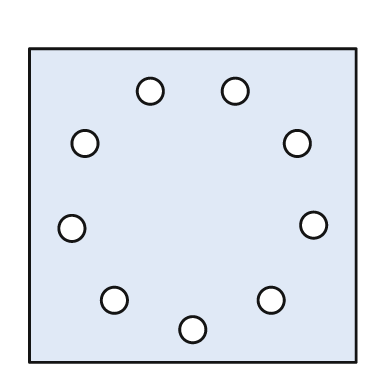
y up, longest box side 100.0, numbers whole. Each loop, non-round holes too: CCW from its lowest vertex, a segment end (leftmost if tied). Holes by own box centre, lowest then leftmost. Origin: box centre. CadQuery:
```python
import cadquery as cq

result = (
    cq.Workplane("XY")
    .moveTo(-50.0, -48.0)
    .lineTo(50.0, -48.0)
    .lineTo(50.0, 48.0)
    .lineTo(-50.0, 48.0)
    .close()
    .moveTo(0.0, -38.0)
    .circle(4.0)
    .moveTo(-24.0, -29.0)
    .circle(4.0)
    .moveTo(24.0, -29.0)
    .circle(4.0)
    .moveTo(-37.0, -7.0)
    .circle(4.0)
    .moveTo(37.0, -6.0)
    .circle(4.0)
    .moveTo(-33.0, 19.0)
    .circle(4.0)
    .moveTo(32.0, 19.0)
    .circle(4.0)
    .moveTo(-13.0, 35.0)
    .circle(4.0)
    .moveTo(13.0, 35.0)
    .circle(4.0)
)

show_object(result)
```